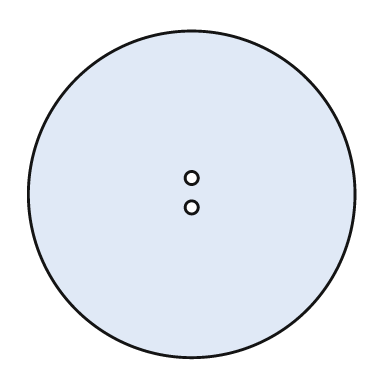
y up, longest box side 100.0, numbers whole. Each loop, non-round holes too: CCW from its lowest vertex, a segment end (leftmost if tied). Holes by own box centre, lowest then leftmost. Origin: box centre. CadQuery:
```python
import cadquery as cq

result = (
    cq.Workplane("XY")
    .moveTo(0.0, 0.0)
    .circle(50.0)
    .moveTo(0.0, -4.0)
    .circle(2.0)
    .moveTo(0.0, 5.0)
    .circle(2.0)
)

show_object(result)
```